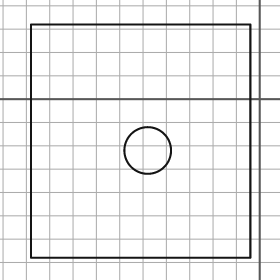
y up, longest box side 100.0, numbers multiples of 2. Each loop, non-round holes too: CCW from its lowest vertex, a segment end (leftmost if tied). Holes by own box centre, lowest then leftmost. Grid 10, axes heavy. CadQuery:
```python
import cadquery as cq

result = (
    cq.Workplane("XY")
    .moveTo(-98.0, -68.0)
    .lineTo(-4.0, -68.0)
    .lineTo(-4.0, 32.0)
    .lineTo(-98.0, 32.0)
    .close()
    .moveTo(-48.0, -22.0)
    .circle(10.0)
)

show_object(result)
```